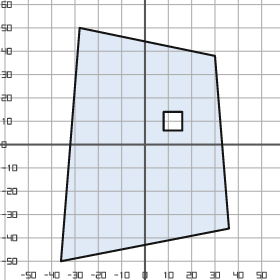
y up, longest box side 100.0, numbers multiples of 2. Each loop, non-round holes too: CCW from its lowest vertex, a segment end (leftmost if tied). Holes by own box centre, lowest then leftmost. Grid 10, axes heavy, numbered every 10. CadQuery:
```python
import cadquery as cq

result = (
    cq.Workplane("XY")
    .moveTo(-36.0, -50.0)
    .lineTo(36.0, -36.0)
    .lineTo(30.0, 38.0)
    .lineTo(-28.0, 50.0)
    .close()
    .moveTo(8.0, 6.0)
    .lineTo(16.0, 6.0)
    .lineTo(16.0, 14.0)
    .lineTo(8.0, 14.0)
    .close()
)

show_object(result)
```